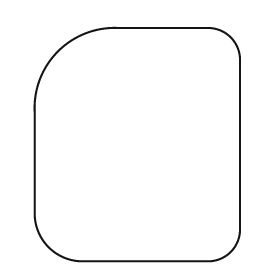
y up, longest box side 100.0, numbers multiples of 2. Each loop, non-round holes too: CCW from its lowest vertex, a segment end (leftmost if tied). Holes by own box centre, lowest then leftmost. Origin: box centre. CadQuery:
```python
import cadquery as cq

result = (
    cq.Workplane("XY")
    .moveTo(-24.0, -50.0)
    .lineTo(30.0, -50.0)
    .threePointArc((40.0, -46.0), (44.0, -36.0))
    .lineTo(44.0, 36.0)
    .threePointArc((40.0, 46.0), (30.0, 50.0))
    .lineTo(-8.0, 50.0)
    .threePointArc((-34.0, 40.0), (-44.0, 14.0))
    .lineTo(-44.0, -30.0)
    .threePointArc((-38.0, -44.0), (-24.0, -50.0))
    .close()
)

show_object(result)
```